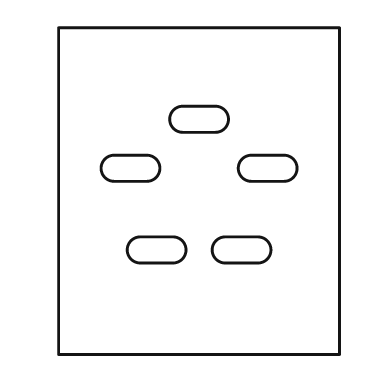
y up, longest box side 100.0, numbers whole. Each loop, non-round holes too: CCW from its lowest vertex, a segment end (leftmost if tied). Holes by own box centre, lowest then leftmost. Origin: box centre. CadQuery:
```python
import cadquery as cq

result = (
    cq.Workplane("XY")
    .moveTo(-43.0, -50.0)
    .lineTo(43.0, -50.0)
    .lineTo(43.0, 50.0)
    .lineTo(-43.0, 50.0)
    .close()
    .moveTo(-18.0, -22.0)
    .lineTo(-8.0, -22.0)
    .threePointArc((-4.0, -18.0), (-8.0, -14.0))
    .lineTo(-18.0, -14.0)
    .threePointArc((-22.0, -18.0), (-18.0, -22.0))
    .close()
    .moveTo(8.0, -22.0)
    .lineTo(18.0, -22.0)
    .threePointArc((22.0, -18.0), (18.0, -14.0))
    .lineTo(8.0, -14.0)
    .threePointArc((4.0, -18.0), (8.0, -22.0))
    .close()
    .moveTo(-26.0, 3.0)
    .lineTo(-16.0, 3.0)
    .threePointArc((-12.0, 7.0), (-16.0, 11.0))
    .lineTo(-26.0, 11.0)
    .threePointArc((-30.0, 7.0), (-26.0, 3.0))
    .close()
    .moveTo(16.0, 3.0)
    .lineTo(26.0, 3.0)
    .threePointArc((30.0, 7.0), (26.0, 11.0))
    .lineTo(16.0, 11.0)
    .threePointArc((12.0, 7.0), (16.0, 3.0))
    .close()
    .moveTo(-5.0, 18.0)
    .lineTo(5.0, 18.0)
    .threePointArc((9.0, 22.0), (5.0, 26.0))
    .lineTo(-5.0, 26.0)
    .threePointArc((-9.0, 22.0), (-5.0, 18.0))
    .close()
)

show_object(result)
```